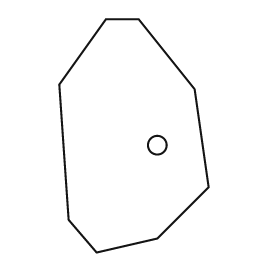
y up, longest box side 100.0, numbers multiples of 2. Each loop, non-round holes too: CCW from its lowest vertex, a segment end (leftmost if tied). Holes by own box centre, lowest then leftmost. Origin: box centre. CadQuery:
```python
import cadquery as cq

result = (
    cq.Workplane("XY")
    .moveTo(-16.0, -50.0)
    .lineTo(10.0, -44.0)
    .lineTo(32.0, -22.0)
    .lineTo(26.0, 20.0)
    .lineTo(2.0, 50.0)
    .lineTo(-12.0, 50.0)
    .lineTo(-32.0, 22.0)
    .lineTo(-28.0, -36.0)
    .close()
    .moveTo(10.0, -4.0)
    .circle(4.0)
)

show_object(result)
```